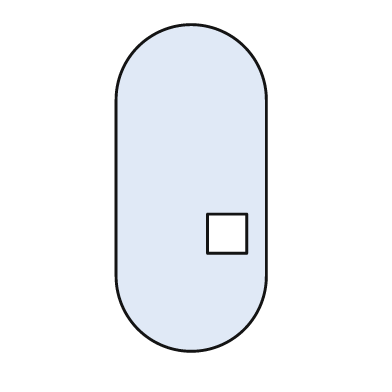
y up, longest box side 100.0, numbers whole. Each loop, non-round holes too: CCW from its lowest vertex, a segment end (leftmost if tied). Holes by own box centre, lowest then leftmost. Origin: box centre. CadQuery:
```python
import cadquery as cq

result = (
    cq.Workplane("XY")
    .moveTo(-23.0, -27.0)
    .threePointArc((0.0, -50.0), (23.0, -27.0))
    .lineTo(23.0, 27.0)
    .threePointArc((0.0, 50.0), (-23.0, 27.0))
    .close()
    .moveTo(5.0, -20.0)
    .lineTo(17.0, -20.0)
    .lineTo(17.0, -8.0)
    .lineTo(5.0, -8.0)
    .close()
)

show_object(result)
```